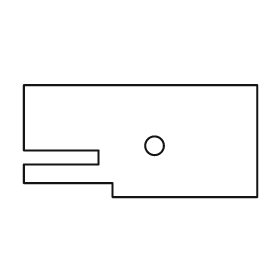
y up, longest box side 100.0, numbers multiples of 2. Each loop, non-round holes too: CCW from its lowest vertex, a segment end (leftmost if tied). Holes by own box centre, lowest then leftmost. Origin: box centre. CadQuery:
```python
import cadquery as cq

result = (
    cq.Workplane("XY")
    .moveTo(-12.0, -24.0)
    .lineTo(50.0, -24.0)
    .lineTo(50.0, 24.0)
    .lineTo(-50.0, 24.0)
    .lineTo(-50.0, -4.0)
    .lineTo(-18.0, -4.0)
    .lineTo(-18.0, -10.0)
    .lineTo(-50.0, -10.0)
    .lineTo(-50.0, -18.0)
    .lineTo(-12.0, -18.0)
    .close()
    .moveTo(6.0, -2.0)
    .circle(4.0)
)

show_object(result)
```